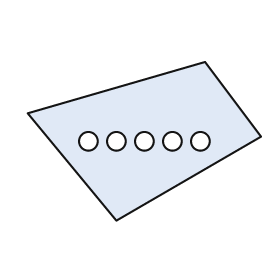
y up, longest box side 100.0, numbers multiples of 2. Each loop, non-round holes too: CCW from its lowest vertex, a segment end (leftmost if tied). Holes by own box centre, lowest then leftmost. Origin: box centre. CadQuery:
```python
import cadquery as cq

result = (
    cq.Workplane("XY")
    .moveTo(-12.0, -34.0)
    .lineTo(50.0, 2.0)
    .lineTo(26.0, 34.0)
    .lineTo(-50.0, 12.0)
    .close()
    .moveTo(-24.0, 0.0)
    .circle(4.0)
    .moveTo(-12.0, 0.0)
    .circle(4.0)
    .moveTo(0.0, 0.0)
    .circle(4.0)
    .moveTo(12.0, 0.0)
    .circle(4.0)
    .moveTo(24.0, 0.0)
    .circle(4.0)
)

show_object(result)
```